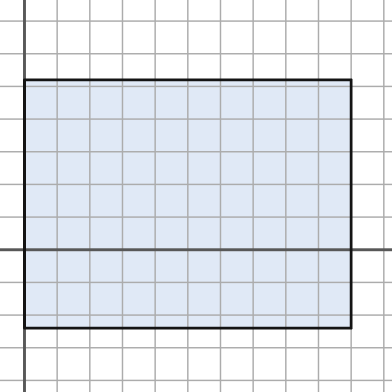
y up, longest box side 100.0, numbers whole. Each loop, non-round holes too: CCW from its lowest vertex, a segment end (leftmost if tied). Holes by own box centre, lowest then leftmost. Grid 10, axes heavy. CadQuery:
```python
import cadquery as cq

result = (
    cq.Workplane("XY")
    .moveTo(0.0, -24.0)
    .lineTo(100.0, -24.0)
    .lineTo(100.0, 52.0)
    .lineTo(0.0, 52.0)
    .close()
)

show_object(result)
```